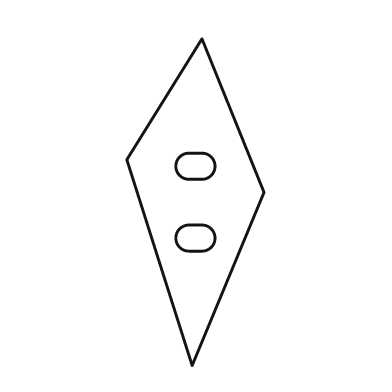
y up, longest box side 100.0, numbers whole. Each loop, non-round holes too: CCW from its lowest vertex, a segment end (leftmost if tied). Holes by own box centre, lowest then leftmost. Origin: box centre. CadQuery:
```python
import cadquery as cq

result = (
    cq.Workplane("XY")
    .moveTo(-1.0, -50.0)
    .lineTo(21.0, 3.0)
    .lineTo(2.0, 50.0)
    .lineTo(-21.0, 13.0)
    .close()
    .moveTo(-2.0, -15.0)
    .lineTo(2.0, -15.0)
    .threePointArc((6.0, -11.0), (2.0, -7.0))
    .lineTo(-2.0, -7.0)
    .threePointArc((-6.0, -11.0), (-2.0, -15.0))
    .close()
    .moveTo(-2.0, 7.0)
    .lineTo(2.0, 7.0)
    .threePointArc((6.0, 11.0), (2.0, 15.0))
    .lineTo(-2.0, 15.0)
    .threePointArc((-6.0, 11.0), (-2.0, 7.0))
    .close()
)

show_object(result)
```